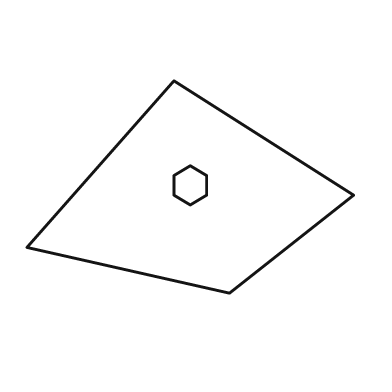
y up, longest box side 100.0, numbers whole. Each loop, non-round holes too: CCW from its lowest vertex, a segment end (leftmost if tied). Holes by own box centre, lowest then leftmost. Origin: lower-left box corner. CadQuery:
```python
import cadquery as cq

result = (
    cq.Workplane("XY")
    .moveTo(62.0, 0.0)
    .lineTo(100.0, 30.0)
    .lineTo(45.0, 65.0)
    .lineTo(0.0, 14.0)
    .close()
    .moveTo(50.0, 27.0)
    .lineTo(55.0, 30.0)
    .lineTo(55.0, 36.0)
    .lineTo(50.0, 39.0)
    .lineTo(45.0, 36.0)
    .lineTo(45.0, 30.0)
    .close()
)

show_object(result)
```